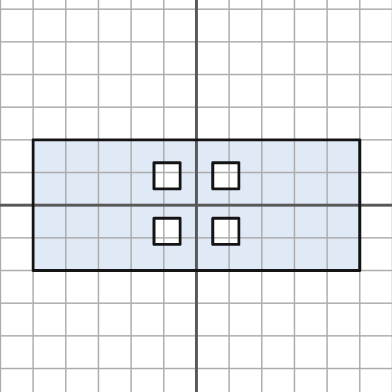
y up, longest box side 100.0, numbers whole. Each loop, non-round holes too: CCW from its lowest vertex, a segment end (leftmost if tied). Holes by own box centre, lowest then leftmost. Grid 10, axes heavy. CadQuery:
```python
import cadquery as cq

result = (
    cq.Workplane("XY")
    .moveTo(-50.0, -20.0)
    .lineTo(50.0, -20.0)
    .lineTo(50.0, 20.0)
    .lineTo(-50.0, 20.0)
    .close()
    .moveTo(-13.0, -12.0)
    .lineTo(-5.0, -12.0)
    .lineTo(-5.0, -4.0)
    .lineTo(-13.0, -4.0)
    .close()
    .moveTo(5.0, -12.0)
    .lineTo(13.0, -12.0)
    .lineTo(13.0, -4.0)
    .lineTo(5.0, -4.0)
    .close()
    .moveTo(-13.0, 5.0)
    .lineTo(-5.0, 5.0)
    .lineTo(-5.0, 13.0)
    .lineTo(-13.0, 13.0)
    .close()
    .moveTo(5.0, 5.0)
    .lineTo(13.0, 5.0)
    .lineTo(13.0, 13.0)
    .lineTo(5.0, 13.0)
    .close()
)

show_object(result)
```